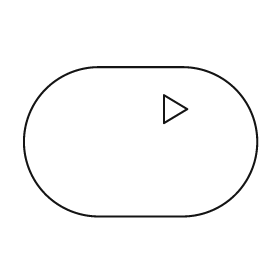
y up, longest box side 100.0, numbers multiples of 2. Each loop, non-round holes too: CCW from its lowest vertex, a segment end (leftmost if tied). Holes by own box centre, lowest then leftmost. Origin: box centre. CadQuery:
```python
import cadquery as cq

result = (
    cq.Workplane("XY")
    .moveTo(-18.0, -32.0)
    .lineTo(18.0, -32.0)
    .threePointArc((50.0, 0.0), (18.0, 32.0))
    .lineTo(-18.0, 32.0)
    .threePointArc((-50.0, 0.0), (-18.0, -32.0))
    .close()
    .moveTo(10.0, 8.0)
    .lineTo(20.0, 14.0)
    .lineTo(10.0, 20.0)
    .close()
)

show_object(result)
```